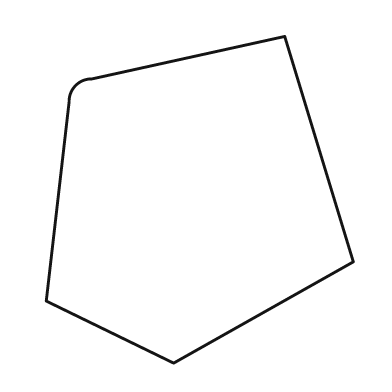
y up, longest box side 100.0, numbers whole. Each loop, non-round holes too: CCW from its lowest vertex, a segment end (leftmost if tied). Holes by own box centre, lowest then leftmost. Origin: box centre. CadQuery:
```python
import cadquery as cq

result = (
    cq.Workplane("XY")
    .moveTo(-8.0, -50.0)
    .lineTo(47.0, -19.0)
    .lineTo(26.0, 50.0)
    .lineTo(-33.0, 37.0)
    .threePointArc((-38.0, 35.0), (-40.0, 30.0))
    .lineTo(-47.0, -31.0)
    .close()
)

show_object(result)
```